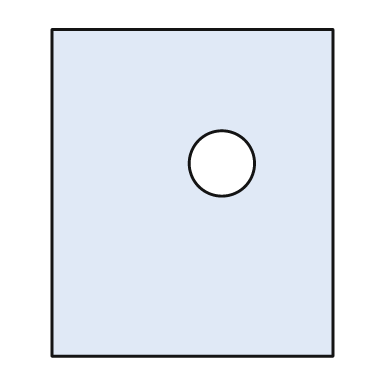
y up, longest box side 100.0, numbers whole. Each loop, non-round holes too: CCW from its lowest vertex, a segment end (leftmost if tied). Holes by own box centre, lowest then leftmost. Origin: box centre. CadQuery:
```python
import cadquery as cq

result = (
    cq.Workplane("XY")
    .moveTo(-43.0, -50.0)
    .lineTo(43.0, -50.0)
    .lineTo(43.0, 50.0)
    .lineTo(-43.0, 50.0)
    .close()
    .moveTo(9.0, 9.0)
    .circle(10.0)
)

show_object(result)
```